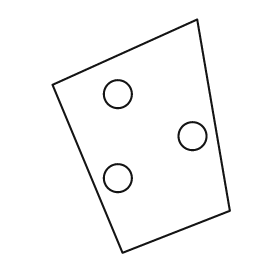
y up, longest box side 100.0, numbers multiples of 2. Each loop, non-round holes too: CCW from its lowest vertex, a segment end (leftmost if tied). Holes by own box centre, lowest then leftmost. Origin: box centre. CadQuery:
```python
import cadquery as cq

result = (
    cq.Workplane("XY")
    .moveTo(-8.0, -50.0)
    .lineTo(38.0, -32.0)
    .lineTo(24.0, 50.0)
    .lineTo(-38.0, 22.0)
    .close()
    .moveTo(-10.0, -18.0)
    .circle(6.0)
    .moveTo(22.0, 0.0)
    .circle(6.0)
    .moveTo(-10.0, 18.0)
    .circle(6.0)
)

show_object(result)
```